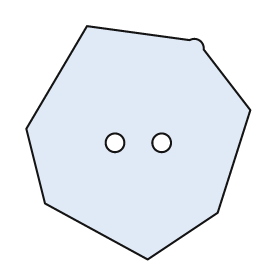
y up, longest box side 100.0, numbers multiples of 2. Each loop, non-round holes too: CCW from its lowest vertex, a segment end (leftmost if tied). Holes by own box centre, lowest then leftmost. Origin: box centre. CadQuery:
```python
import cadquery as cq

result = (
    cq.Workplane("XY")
    .moveTo(4.0, -50.0)
    .lineTo(34.0, -30.0)
    .lineTo(48.0, 14.0)
    .lineTo(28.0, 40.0)
    .threePointArc((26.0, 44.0), (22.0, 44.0))
    .lineTo(-22.0, 50.0)
    .lineTo(-48.0, 6.0)
    .lineTo(-40.0, -26.0)
    .close()
    .moveTo(-10.0, 0.0)
    .circle(4.0)
    .moveTo(10.0, 0.0)
    .circle(4.0)
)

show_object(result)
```